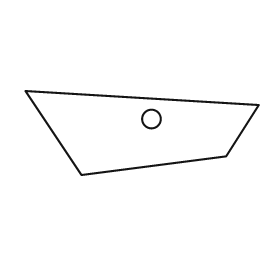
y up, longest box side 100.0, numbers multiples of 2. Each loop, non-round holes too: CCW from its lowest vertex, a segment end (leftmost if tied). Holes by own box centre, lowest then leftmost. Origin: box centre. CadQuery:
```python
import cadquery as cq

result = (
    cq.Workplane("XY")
    .moveTo(-26.0, -18.0)
    .lineTo(36.0, -10.0)
    .lineTo(50.0, 12.0)
    .lineTo(-50.0, 18.0)
    .close()
    .moveTo(4.0, 6.0)
    .circle(4.0)
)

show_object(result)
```